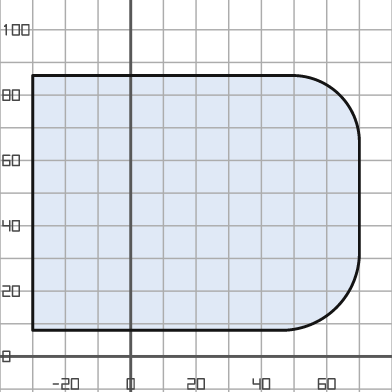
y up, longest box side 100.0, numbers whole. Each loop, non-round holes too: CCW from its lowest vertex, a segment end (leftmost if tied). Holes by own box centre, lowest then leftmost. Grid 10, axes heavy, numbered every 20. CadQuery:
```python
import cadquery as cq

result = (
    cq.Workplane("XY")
    .moveTo(-30.0, 8.0)
    .lineTo(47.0, 8.0)
    .threePointArc((63.0, 15.0), (70.0, 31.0))
    .lineTo(70.0, 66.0)
    .threePointArc((64.0, 80.0), (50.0, 86.0))
    .lineTo(-30.0, 86.0)
    .close()
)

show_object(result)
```